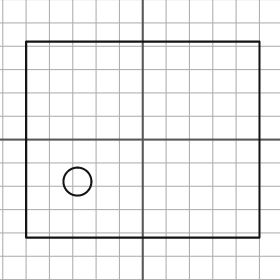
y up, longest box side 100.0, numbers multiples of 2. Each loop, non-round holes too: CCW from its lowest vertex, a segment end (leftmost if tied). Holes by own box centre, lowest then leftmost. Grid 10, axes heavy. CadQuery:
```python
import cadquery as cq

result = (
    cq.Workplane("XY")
    .moveTo(-50.0, -42.0)
    .lineTo(50.0, -42.0)
    .lineTo(50.0, 42.0)
    .lineTo(-50.0, 42.0)
    .close()
    .moveTo(-28.0, -18.0)
    .circle(6.0)
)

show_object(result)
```